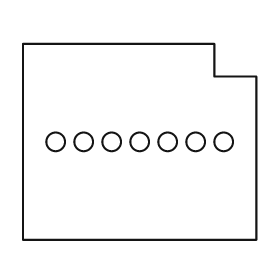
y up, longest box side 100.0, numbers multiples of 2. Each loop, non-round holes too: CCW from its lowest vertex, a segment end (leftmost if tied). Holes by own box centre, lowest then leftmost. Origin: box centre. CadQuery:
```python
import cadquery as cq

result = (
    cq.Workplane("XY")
    .moveTo(-50.0, -42.0)
    .lineTo(50.0, -42.0)
    .lineTo(50.0, 28.0)
    .lineTo(32.0, 28.0)
    .lineTo(32.0, 42.0)
    .lineTo(-50.0, 42.0)
    .close()
    .moveTo(-36.0, 0.0)
    .circle(4.0)
    .moveTo(-24.0, 0.0)
    .circle(4.0)
    .moveTo(-12.0, 0.0)
    .circle(4.0)
    .moveTo(0.0, 0.0)
    .circle(4.0)
    .moveTo(12.0, 0.0)
    .circle(4.0)
    .moveTo(24.0, 0.0)
    .circle(4.0)
    .moveTo(36.0, 0.0)
    .circle(4.0)
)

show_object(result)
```